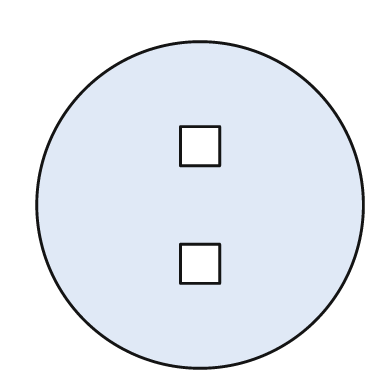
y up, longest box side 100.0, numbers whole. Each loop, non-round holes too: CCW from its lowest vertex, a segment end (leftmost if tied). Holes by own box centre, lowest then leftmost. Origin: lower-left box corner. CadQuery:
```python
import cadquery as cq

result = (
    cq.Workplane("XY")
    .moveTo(50.0, 50.0)
    .circle(50.0)
    .moveTo(44.0, 26.0)
    .lineTo(56.0, 26.0)
    .lineTo(56.0, 38.0)
    .lineTo(44.0, 38.0)
    .close()
    .moveTo(44.0, 62.0)
    .lineTo(56.0, 62.0)
    .lineTo(56.0, 74.0)
    .lineTo(44.0, 74.0)
    .close()
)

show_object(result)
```